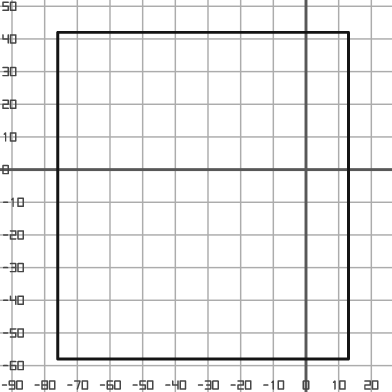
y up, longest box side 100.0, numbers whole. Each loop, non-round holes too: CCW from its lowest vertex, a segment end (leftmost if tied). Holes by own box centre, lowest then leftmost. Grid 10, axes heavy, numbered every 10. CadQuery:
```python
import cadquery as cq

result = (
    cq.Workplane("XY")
    .moveTo(-76.0, -58.0)
    .lineTo(13.0, -58.0)
    .lineTo(13.0, 42.0)
    .lineTo(-76.0, 42.0)
    .close()
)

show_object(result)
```